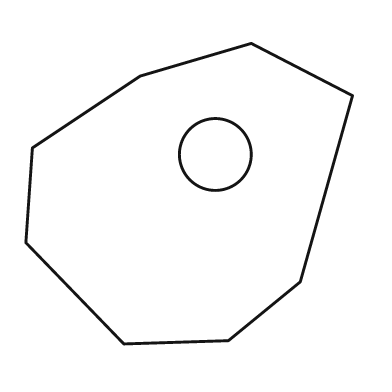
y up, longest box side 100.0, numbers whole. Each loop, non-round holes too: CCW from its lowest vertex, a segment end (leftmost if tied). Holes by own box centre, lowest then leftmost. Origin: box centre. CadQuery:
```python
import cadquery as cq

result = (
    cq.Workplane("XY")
    .moveTo(-20.0, -46.0)
    .lineTo(12.0, -45.0)
    .lineTo(34.0, -27.0)
    .lineTo(50.0, 30.0)
    .lineTo(19.0, 46.0)
    .lineTo(-15.0, 36.0)
    .lineTo(-48.0, 14.0)
    .lineTo(-50.0, -15.0)
    .close()
    .moveTo(8.0, 12.0)
    .circle(11.0)
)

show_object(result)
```